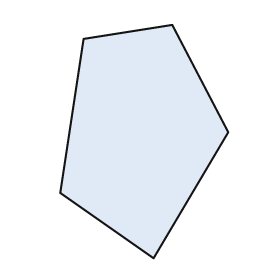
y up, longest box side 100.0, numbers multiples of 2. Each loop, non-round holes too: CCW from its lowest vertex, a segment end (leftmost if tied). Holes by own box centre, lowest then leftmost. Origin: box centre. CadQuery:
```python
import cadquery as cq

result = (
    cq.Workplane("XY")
    .moveTo(4.0, -50.0)
    .lineTo(36.0, 4.0)
    .lineTo(12.0, 50.0)
    .lineTo(-26.0, 44.0)
    .lineTo(-36.0, -22.0)
    .close()
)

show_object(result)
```